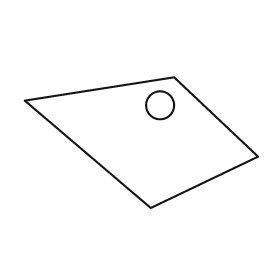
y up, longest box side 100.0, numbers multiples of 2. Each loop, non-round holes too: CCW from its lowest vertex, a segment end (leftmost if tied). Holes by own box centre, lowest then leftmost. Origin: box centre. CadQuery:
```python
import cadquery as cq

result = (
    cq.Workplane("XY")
    .moveTo(4.0, -28.0)
    .lineTo(50.0, -6.0)
    .lineTo(14.0, 28.0)
    .lineTo(-50.0, 18.0)
    .close()
    .moveTo(8.0, 16.0)
    .circle(6.0)
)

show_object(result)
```